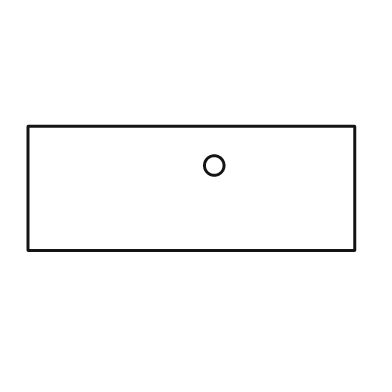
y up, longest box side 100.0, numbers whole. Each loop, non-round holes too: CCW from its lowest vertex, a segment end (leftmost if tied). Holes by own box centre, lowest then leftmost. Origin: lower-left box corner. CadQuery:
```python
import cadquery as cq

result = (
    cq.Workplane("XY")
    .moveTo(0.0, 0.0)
    .lineTo(100.0, 0.0)
    .lineTo(100.0, 38.0)
    .lineTo(0.0, 38.0)
    .close()
    .moveTo(57.0, 26.0)
    .circle(3.0)
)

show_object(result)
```